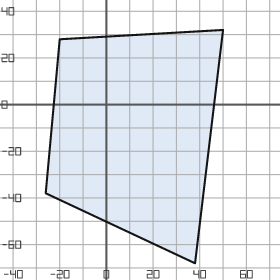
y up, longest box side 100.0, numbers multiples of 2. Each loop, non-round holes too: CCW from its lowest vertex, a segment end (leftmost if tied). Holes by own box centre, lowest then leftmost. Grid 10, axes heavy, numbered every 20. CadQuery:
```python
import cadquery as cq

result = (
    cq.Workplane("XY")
    .moveTo(38.0, -68.0)
    .lineTo(50.0, 32.0)
    .lineTo(-20.0, 28.0)
    .lineTo(-26.0, -38.0)
    .close()
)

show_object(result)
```